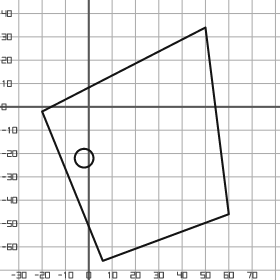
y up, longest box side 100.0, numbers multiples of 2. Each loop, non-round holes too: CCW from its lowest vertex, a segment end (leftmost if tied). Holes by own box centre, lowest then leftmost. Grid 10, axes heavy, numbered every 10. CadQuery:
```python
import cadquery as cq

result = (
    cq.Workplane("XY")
    .moveTo(6.0, -66.0)
    .lineTo(60.0, -46.0)
    .lineTo(50.0, 34.0)
    .lineTo(-20.0, -2.0)
    .close()
    .moveTo(-2.0, -22.0)
    .circle(4.0)
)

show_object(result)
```